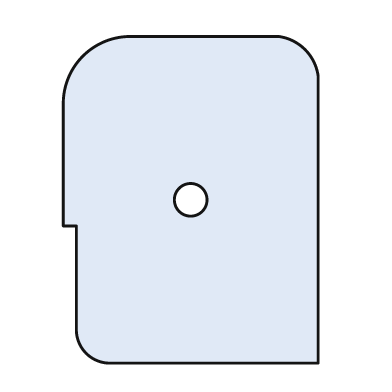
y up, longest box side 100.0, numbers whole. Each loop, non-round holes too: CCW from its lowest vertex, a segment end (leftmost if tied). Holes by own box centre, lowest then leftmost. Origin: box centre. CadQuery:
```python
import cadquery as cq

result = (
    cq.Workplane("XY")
    .moveTo(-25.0, -50.0)
    .lineTo(39.0, -50.0)
    .lineTo(39.0, 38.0)
    .threePointArc((35.0, 46.0), (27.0, 50.0))
    .lineTo(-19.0, 50.0)
    .threePointArc((-33.0, 44.0), (-39.0, 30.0))
    .lineTo(-39.0, -8.0)
    .lineTo(-35.0, -8.0)
    .lineTo(-35.0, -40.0)
    .threePointArc((-32.0, -47.0), (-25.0, -50.0))
    .close()
    .moveTo(0.0, 0.0)
    .circle(5.0)
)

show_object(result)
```